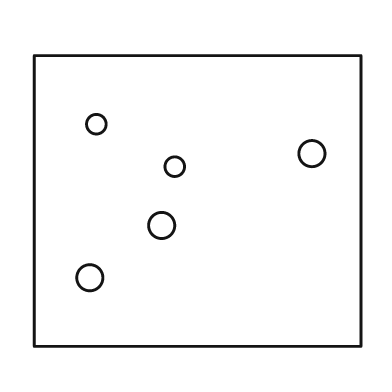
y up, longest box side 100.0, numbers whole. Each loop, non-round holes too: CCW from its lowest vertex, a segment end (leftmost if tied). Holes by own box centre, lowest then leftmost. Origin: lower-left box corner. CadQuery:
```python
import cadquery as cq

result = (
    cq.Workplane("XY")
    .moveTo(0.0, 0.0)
    .lineTo(100.0, 0.0)
    .lineTo(100.0, 89.0)
    .lineTo(0.0, 89.0)
    .close()
    .moveTo(17.0, 21.0)
    .circle(4.0)
    .moveTo(39.0, 37.0)
    .circle(4.0)
    .moveTo(43.0, 55.0)
    .circle(3.0)
    .moveTo(85.0, 59.0)
    .circle(4.0)
    .moveTo(19.0, 68.0)
    .circle(3.0)
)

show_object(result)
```